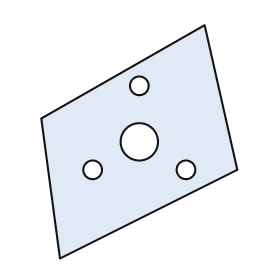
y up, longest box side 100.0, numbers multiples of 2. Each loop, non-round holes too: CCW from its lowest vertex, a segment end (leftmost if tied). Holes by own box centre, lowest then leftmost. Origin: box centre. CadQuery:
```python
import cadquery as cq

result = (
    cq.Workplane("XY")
    .moveTo(-34.0, -50.0)
    .lineTo(42.0, -12.0)
    .lineTo(28.0, 50.0)
    .lineTo(-42.0, 10.0)
    .close()
    .moveTo(-20.0, -12.0)
    .circle(4.0)
    .moveTo(20.0, -12.0)
    .circle(4.0)
    .moveTo(0.0, 0.0)
    .circle(8.0)
    .moveTo(0.0, 24.0)
    .circle(4.0)
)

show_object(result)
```